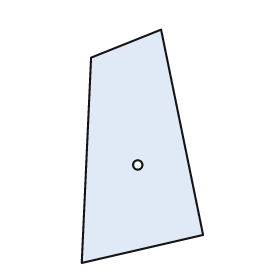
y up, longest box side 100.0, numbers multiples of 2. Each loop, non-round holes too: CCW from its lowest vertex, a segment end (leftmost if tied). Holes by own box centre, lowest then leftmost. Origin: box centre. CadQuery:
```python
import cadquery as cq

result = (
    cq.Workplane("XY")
    .moveTo(-26.0, -50.0)
    .lineTo(26.0, -38.0)
    .lineTo(8.0, 50.0)
    .lineTo(-22.0, 38.0)
    .close()
    .moveTo(-2.0, -8.0)
    .circle(2.0)
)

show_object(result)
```